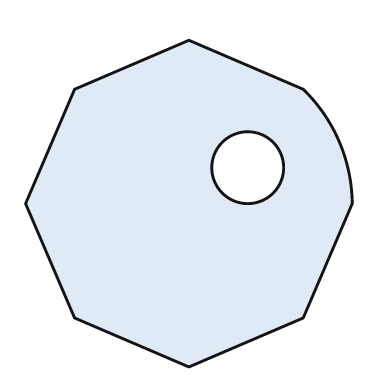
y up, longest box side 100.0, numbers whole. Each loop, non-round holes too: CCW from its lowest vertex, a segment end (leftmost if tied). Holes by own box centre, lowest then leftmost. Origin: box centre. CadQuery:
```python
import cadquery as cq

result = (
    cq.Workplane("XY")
    .moveTo(0.0, -50.0)
    .lineTo(35.0, -35.0)
    .lineTo(50.0, 0.0)
    .threePointArc((46.0, 19.0), (35.0, 35.0))
    .lineTo(0.0, 50.0)
    .lineTo(-35.0, 35.0)
    .lineTo(-50.0, 0.0)
    .lineTo(-35.0, -35.0)
    .close()
    .moveTo(18.0, 11.0)
    .circle(11.0)
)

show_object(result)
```